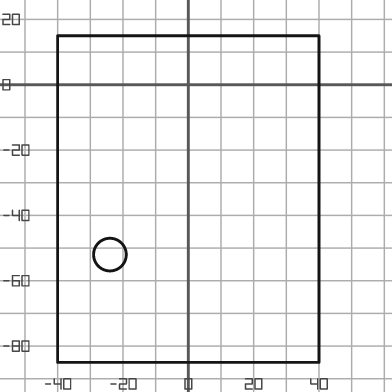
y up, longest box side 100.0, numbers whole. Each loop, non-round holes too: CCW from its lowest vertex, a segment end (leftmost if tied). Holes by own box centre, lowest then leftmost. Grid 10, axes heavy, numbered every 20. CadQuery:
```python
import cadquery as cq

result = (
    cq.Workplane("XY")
    .moveTo(-40.0, -85.0)
    .lineTo(40.0, -85.0)
    .lineTo(40.0, 15.0)
    .lineTo(-40.0, 15.0)
    .close()
    .moveTo(-24.0, -52.0)
    .circle(5.0)
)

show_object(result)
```